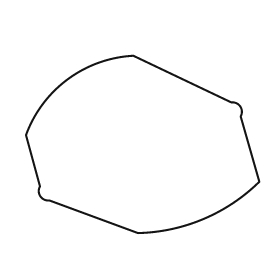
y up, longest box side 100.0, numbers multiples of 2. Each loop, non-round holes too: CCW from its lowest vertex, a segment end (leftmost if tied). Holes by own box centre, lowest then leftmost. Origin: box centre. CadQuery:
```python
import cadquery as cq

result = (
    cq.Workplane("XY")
    .moveTo(-2.0, -38.0)
    .threePointArc((26.0, -32.0), (50.0, -16.0))
    .lineTo(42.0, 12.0)
    .threePointArc((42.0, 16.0), (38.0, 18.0))
    .lineTo(-4.0, 38.0)
    .threePointArc((-32.0, 28.0), (-50.0, 4.0))
    .lineTo(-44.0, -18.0)
    .threePointArc((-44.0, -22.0), (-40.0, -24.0))
    .close()
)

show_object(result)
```